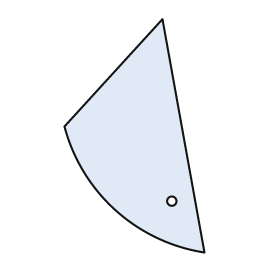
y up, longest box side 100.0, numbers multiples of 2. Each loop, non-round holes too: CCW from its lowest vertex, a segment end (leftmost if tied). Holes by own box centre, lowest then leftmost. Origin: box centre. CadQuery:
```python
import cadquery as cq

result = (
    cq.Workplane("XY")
    .moveTo(30.0, -50.0)
    .lineTo(12.0, 50.0)
    .lineTo(-30.0, 4.0)
    .threePointArc((-8.0, -32.0), (30.0, -50.0))
    .close()
    .moveTo(16.0, -28.0)
    .circle(2.0)
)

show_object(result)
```